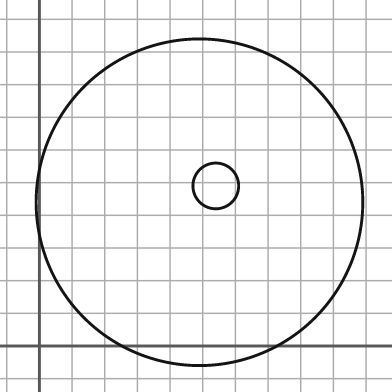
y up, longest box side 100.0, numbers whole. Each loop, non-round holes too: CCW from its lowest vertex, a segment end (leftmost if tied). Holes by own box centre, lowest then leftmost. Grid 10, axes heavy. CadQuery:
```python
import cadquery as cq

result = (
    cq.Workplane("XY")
    .moveTo(49.0, 44.0)
    .circle(50.0)
    .moveTo(54.0, 49.0)
    .circle(7.0)
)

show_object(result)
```